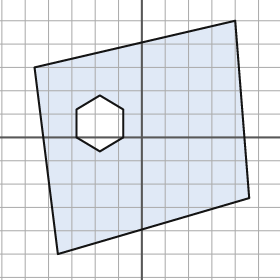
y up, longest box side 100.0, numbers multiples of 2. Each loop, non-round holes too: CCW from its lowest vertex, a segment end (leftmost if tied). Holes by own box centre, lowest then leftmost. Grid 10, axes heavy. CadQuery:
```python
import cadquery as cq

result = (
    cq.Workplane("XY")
    .moveTo(-36.0, -50.0)
    .lineTo(46.0, -26.0)
    .lineTo(40.0, 50.0)
    .lineTo(-46.0, 30.0)
    .close()
    .moveTo(-18.0, -6.0)
    .lineTo(-8.0, 0.0)
    .lineTo(-8.0, 12.0)
    .lineTo(-18.0, 18.0)
    .lineTo(-28.0, 12.0)
    .lineTo(-28.0, 0.0)
    .close()
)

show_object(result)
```